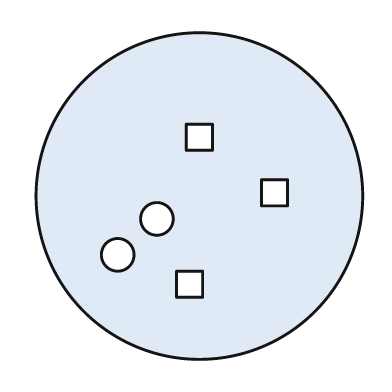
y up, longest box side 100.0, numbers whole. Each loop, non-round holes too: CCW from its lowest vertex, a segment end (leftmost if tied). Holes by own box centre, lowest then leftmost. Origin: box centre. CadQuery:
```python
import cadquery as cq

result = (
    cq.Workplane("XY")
    .moveTo(0.0, 0.0)
    .circle(50.0)
    .moveTo(-7.0, -31.0)
    .lineTo(1.0, -31.0)
    .lineTo(1.0, -23.0)
    .lineTo(-7.0, -23.0)
    .close()
    .moveTo(-25.0, -18.0)
    .circle(5.0)
    .moveTo(-13.0, -7.0)
    .circle(5.0)
    .moveTo(19.0, -3.0)
    .lineTo(27.0, -3.0)
    .lineTo(27.0, 5.0)
    .lineTo(19.0, 5.0)
    .close()
    .moveTo(-4.0, 14.0)
    .lineTo(4.0, 14.0)
    .lineTo(4.0, 22.0)
    .lineTo(-4.0, 22.0)
    .close()
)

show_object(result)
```